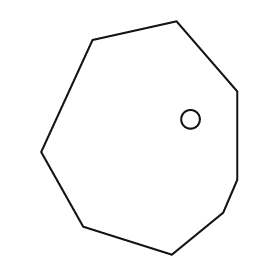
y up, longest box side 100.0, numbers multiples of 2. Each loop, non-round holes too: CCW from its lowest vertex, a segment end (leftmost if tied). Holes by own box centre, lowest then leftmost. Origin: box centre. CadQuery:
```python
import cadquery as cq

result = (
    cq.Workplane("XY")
    .moveTo(14.0, -50.0)
    .lineTo(36.0, -32.0)
    .lineTo(42.0, -18.0)
    .lineTo(42.0, 20.0)
    .lineTo(16.0, 50.0)
    .lineTo(-20.0, 42.0)
    .lineTo(-42.0, -6.0)
    .lineTo(-24.0, -38.0)
    .close()
    .moveTo(22.0, 8.0)
    .circle(4.0)
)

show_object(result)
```